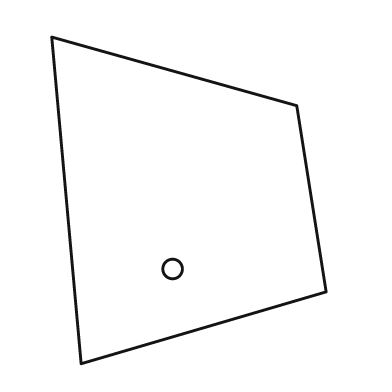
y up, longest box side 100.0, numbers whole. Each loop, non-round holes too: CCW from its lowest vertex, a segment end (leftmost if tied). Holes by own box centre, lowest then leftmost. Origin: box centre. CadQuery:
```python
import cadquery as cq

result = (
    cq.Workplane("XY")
    .moveTo(-33.0, -50.0)
    .lineTo(42.0, -28.0)
    .lineTo(33.0, 29.0)
    .lineTo(-42.0, 50.0)
    .close()
    .moveTo(-5.0, -21.0)
    .circle(3.0)
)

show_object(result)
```